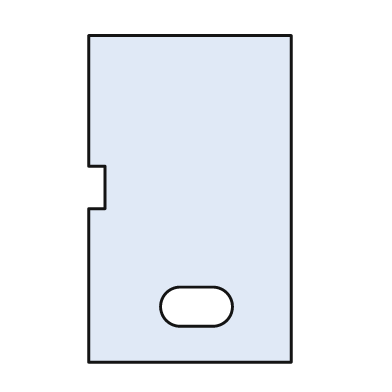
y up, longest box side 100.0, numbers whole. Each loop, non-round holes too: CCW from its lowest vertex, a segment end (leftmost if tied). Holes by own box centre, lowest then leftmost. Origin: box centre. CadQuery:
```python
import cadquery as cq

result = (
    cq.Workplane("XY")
    .moveTo(-31.0, -50.0)
    .lineTo(31.0, -50.0)
    .lineTo(31.0, 50.0)
    .lineTo(-31.0, 50.0)
    .lineTo(-31.0, 10.0)
    .lineTo(-26.0, 10.0)
    .lineTo(-26.0, -3.0)
    .lineTo(-31.0, -3.0)
    .close()
    .moveTo(-3.0, -39.0)
    .lineTo(7.0, -39.0)
    .threePointArc((13.0, -33.0), (7.0, -27.0))
    .lineTo(-3.0, -27.0)
    .threePointArc((-9.0, -33.0), (-3.0, -39.0))
    .close()
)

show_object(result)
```